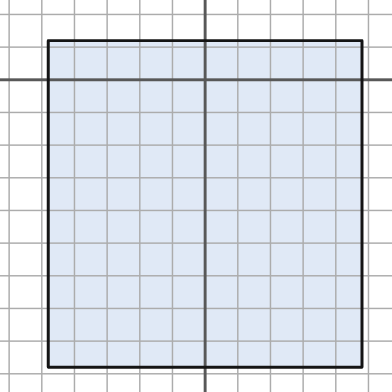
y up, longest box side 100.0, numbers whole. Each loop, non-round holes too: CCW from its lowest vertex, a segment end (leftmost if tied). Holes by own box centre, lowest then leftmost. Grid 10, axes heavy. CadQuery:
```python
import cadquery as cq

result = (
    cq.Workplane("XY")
    .moveTo(-48.0, -88.0)
    .lineTo(48.0, -88.0)
    .lineTo(48.0, 12.0)
    .lineTo(-48.0, 12.0)
    .close()
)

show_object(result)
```